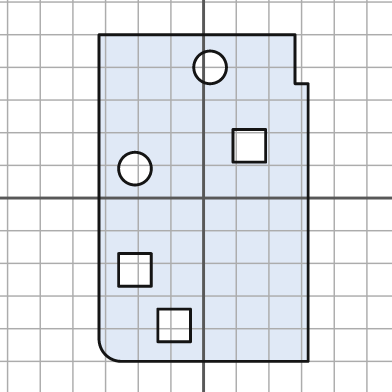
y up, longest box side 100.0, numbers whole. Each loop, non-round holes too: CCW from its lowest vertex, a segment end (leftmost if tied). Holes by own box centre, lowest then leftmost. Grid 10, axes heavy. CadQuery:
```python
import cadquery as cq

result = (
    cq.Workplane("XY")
    .moveTo(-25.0, -50.0)
    .lineTo(32.0, -50.0)
    .lineTo(32.0, 35.0)
    .lineTo(28.0, 35.0)
    .lineTo(28.0, 50.0)
    .lineTo(-32.0, 50.0)
    .lineTo(-32.0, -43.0)
    .threePointArc((-30.0, -48.0), (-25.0, -50.0))
    .close()
    .moveTo(-14.0, -44.0)
    .lineTo(-4.0, -44.0)
    .lineTo(-4.0, -34.0)
    .lineTo(-14.0, -34.0)
    .close()
    .moveTo(-26.0, -27.0)
    .lineTo(-16.0, -27.0)
    .lineTo(-16.0, -17.0)
    .lineTo(-26.0, -17.0)
    .close()
    .moveTo(-21.0, 9.0)
    .circle(5.0)
    .moveTo(9.0, 11.0)
    .lineTo(19.0, 11.0)
    .lineTo(19.0, 21.0)
    .lineTo(9.0, 21.0)
    .close()
    .moveTo(2.0, 40.0)
    .circle(5.0)
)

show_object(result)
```